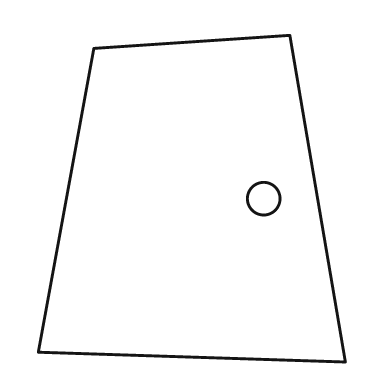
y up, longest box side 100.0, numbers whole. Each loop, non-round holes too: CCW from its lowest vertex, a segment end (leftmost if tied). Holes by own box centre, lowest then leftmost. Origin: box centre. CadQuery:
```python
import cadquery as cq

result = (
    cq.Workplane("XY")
    .moveTo(47.0, -50.0)
    .lineTo(30.0, 50.0)
    .lineTo(-30.0, 46.0)
    .lineTo(-47.0, -47.0)
    .close()
    .moveTo(22.0, 0.0)
    .circle(5.0)
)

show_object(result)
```